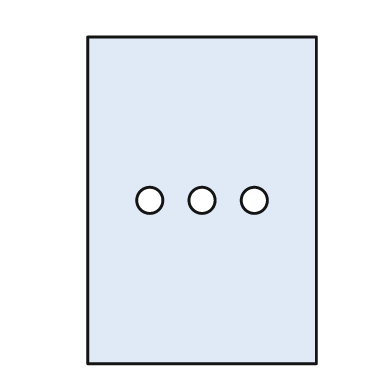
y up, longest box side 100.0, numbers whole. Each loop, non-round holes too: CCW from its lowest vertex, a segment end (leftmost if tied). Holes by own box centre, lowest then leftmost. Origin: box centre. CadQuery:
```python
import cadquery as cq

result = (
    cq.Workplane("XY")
    .moveTo(-35.0, -50.0)
    .lineTo(35.0, -50.0)
    .lineTo(35.0, 50.0)
    .lineTo(-35.0, 50.0)
    .close()
    .moveTo(-16.0, 0.0)
    .circle(4.0)
    .moveTo(0.0, 0.0)
    .circle(4.0)
    .moveTo(16.0, 0.0)
    .circle(4.0)
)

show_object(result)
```